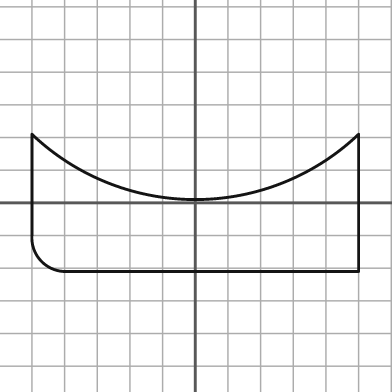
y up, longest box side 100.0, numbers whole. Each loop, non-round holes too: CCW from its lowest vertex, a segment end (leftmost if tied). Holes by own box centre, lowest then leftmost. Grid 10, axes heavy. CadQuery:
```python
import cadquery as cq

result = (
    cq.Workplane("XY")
    .moveTo(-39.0, -21.0)
    .lineTo(50.0, -21.0)
    .lineTo(50.0, 21.0)
    .threePointArc((0.0, 1.0), (-50.0, 21.0))
    .lineTo(-50.0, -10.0)
    .threePointArc((-47.0, -18.0), (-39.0, -21.0))
    .close()
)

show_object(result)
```